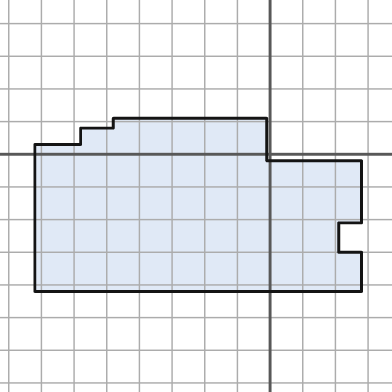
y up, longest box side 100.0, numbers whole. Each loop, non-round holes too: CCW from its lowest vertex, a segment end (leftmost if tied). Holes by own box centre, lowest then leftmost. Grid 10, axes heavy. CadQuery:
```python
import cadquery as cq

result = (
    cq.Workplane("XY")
    .moveTo(-72.0, -42.0)
    .lineTo(28.0, -42.0)
    .lineTo(28.0, -30.0)
    .lineTo(21.0, -30.0)
    .lineTo(21.0, -21.0)
    .lineTo(28.0, -21.0)
    .lineTo(28.0, -2.0)
    .lineTo(-1.0, -2.0)
    .lineTo(-1.0, 11.0)
    .lineTo(-48.0, 11.0)
    .lineTo(-48.0, 8.0)
    .lineTo(-58.0, 8.0)
    .lineTo(-58.0, 3.0)
    .lineTo(-72.0, 3.0)
    .close()
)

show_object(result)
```